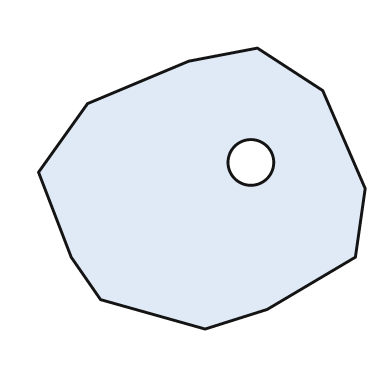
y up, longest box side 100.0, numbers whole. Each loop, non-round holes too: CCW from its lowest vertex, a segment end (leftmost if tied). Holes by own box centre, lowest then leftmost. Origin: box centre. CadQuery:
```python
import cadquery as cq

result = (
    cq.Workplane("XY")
    .moveTo(1.0, -43.0)
    .lineTo(20.0, -37.0)
    .lineTo(47.0, -21.0)
    .lineTo(50.0, 0.0)
    .lineTo(37.0, 30.0)
    .lineTo(17.0, 43.0)
    .lineTo(-4.0, 39.0)
    .lineTo(-35.0, 26.0)
    .lineTo(-50.0, 5.0)
    .lineTo(-40.0, -21.0)
    .lineTo(-31.0, -34.0)
    .close()
    .moveTo(15.0, 8.0)
    .circle(7.0)
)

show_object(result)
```